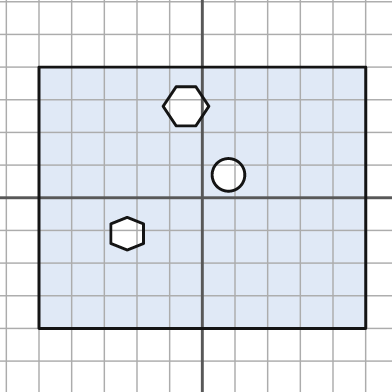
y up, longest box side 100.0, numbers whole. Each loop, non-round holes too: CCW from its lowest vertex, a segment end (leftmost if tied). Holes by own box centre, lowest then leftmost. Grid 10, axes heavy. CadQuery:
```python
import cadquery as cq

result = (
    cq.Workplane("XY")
    .moveTo(-50.0, -40.0)
    .lineTo(50.0, -40.0)
    .lineTo(50.0, 40.0)
    .lineTo(-50.0, 40.0)
    .close()
    .moveTo(-23.0, -16.0)
    .lineTo(-18.0, -14.0)
    .lineTo(-18.0, -8.0)
    .lineTo(-23.0, -6.0)
    .lineTo(-28.0, -8.0)
    .lineTo(-28.0, -14.0)
    .close()
    .moveTo(8.0, 7.0)
    .circle(5.0)
    .moveTo(-8.0, 22.0)
    .lineTo(-2.0, 22.0)
    .lineTo(2.0, 28.0)
    .lineTo(-2.0, 34.0)
    .lineTo(-8.0, 34.0)
    .lineTo(-12.0, 28.0)
    .close()
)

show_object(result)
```